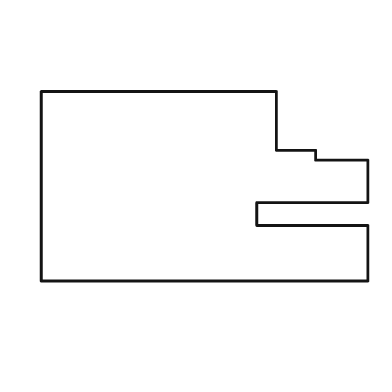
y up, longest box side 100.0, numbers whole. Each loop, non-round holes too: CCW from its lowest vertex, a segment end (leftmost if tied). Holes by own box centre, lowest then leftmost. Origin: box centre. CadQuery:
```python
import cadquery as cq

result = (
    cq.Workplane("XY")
    .moveTo(-50.0, -29.0)
    .lineTo(50.0, -29.0)
    .lineTo(50.0, -12.0)
    .lineTo(16.0, -12.0)
    .lineTo(16.0, -5.0)
    .lineTo(50.0, -5.0)
    .lineTo(50.0, 8.0)
    .lineTo(34.0, 8.0)
    .lineTo(34.0, 11.0)
    .lineTo(22.0, 11.0)
    .lineTo(22.0, 29.0)
    .lineTo(-50.0, 29.0)
    .close()
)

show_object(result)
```